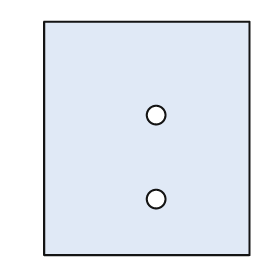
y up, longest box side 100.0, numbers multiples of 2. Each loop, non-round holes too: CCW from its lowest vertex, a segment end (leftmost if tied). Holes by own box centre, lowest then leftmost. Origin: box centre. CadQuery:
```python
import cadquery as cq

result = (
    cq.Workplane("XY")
    .moveTo(-44.0, -50.0)
    .lineTo(44.0, -50.0)
    .lineTo(44.0, 50.0)
    .lineTo(-44.0, 50.0)
    .close()
    .moveTo(4.0, -26.0)
    .circle(4.0)
    .moveTo(4.0, 10.0)
    .circle(4.0)
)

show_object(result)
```